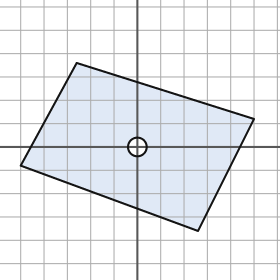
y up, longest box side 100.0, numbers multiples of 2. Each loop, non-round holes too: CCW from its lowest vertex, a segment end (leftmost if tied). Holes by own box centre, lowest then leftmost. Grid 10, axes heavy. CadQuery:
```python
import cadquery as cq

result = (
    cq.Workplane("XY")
    .moveTo(26.0, -36.0)
    .lineTo(50.0, 12.0)
    .lineTo(-26.0, 36.0)
    .lineTo(-50.0, -8.0)
    .close()
    .moveTo(0.0, 0.0)
    .circle(4.0)
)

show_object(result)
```